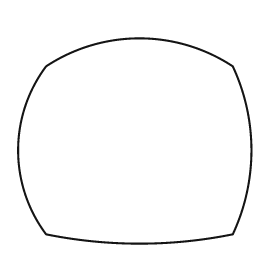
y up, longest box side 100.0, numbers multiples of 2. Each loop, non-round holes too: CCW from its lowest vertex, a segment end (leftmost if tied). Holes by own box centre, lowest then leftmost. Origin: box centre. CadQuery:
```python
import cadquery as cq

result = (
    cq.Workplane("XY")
    .moveTo(-38.0, -40.0)
    .threePointArc((2.0, -44.0), (42.0, -40.0))
    .threePointArc((50.0, -4.0), (42.0, 32.0))
    .threePointArc((2.0, 44.0), (-38.0, 32.0))
    .threePointArc((-50.0, -4.0), (-38.0, -40.0))
    .close()
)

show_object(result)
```